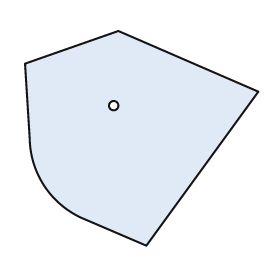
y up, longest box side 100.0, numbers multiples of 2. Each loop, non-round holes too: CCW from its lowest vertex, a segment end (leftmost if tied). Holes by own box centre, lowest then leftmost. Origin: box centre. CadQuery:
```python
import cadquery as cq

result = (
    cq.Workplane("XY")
    .moveTo(2.0, -46.0)
    .lineTo(50.0, 20.0)
    .lineTo(-10.0, 46.0)
    .lineTo(-50.0, 32.0)
    .lineTo(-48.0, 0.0)
    .threePointArc((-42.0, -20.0), (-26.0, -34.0))
    .close()
    .moveTo(-12.0, 14.0)
    .circle(2.0)
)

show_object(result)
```